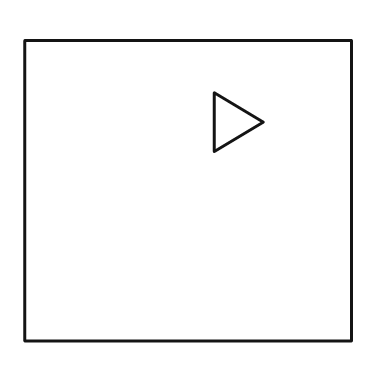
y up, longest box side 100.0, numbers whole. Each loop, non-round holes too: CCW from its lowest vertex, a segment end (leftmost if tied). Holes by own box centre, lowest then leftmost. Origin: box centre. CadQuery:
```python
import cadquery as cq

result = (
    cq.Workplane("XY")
    .moveTo(-50.0, -46.0)
    .lineTo(50.0, -46.0)
    .lineTo(50.0, 46.0)
    .lineTo(-50.0, 46.0)
    .close()
    .moveTo(8.0, 12.0)
    .lineTo(23.0, 21.0)
    .lineTo(8.0, 30.0)
    .close()
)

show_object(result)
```